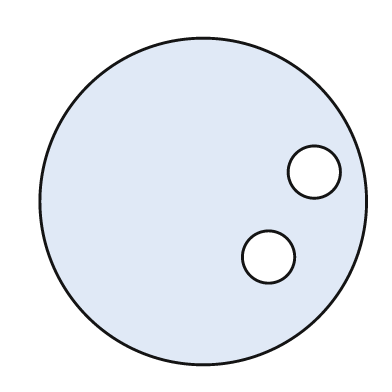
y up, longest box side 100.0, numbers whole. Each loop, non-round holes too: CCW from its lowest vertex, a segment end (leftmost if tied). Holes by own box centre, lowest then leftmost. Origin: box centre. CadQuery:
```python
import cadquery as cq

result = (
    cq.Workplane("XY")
    .moveTo(0.0, 0.0)
    .circle(50.0)
    .moveTo(20.0, -17.0)
    .circle(8.0)
    .moveTo(34.0, 9.0)
    .circle(8.0)
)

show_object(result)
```